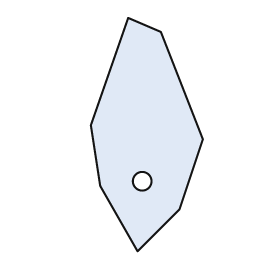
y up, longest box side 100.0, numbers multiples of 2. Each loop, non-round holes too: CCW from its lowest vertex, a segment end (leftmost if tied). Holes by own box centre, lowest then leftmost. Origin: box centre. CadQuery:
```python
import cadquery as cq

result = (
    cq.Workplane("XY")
    .moveTo(-4.0, -50.0)
    .lineTo(14.0, -32.0)
    .lineTo(24.0, -2.0)
    .lineTo(6.0, 44.0)
    .lineTo(-8.0, 50.0)
    .lineTo(-24.0, 4.0)
    .lineTo(-20.0, -22.0)
    .close()
    .moveTo(-2.0, -20.0)
    .circle(4.0)
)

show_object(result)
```